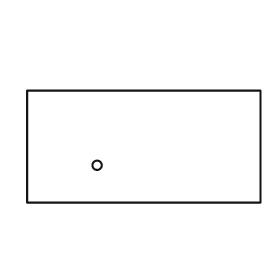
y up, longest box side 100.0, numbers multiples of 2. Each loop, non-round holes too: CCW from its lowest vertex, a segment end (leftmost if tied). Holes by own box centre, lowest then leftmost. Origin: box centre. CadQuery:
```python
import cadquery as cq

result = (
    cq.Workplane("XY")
    .moveTo(-50.0, -24.0)
    .lineTo(50.0, -24.0)
    .lineTo(50.0, 24.0)
    .lineTo(-50.0, 24.0)
    .close()
    .moveTo(-20.0, -8.0)
    .circle(2.0)
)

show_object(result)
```